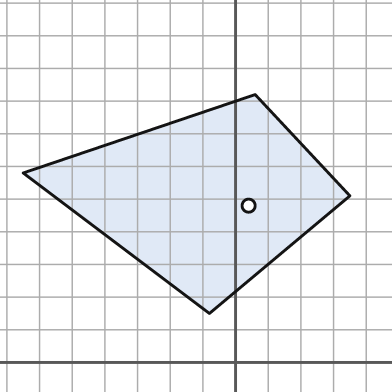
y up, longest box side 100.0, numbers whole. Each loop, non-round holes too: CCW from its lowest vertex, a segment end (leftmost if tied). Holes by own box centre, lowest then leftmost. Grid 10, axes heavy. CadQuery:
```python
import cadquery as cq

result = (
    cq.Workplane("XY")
    .moveTo(-8.0, 15.0)
    .lineTo(35.0, 51.0)
    .lineTo(6.0, 82.0)
    .lineTo(-65.0, 58.0)
    .close()
    .moveTo(4.0, 48.0)
    .circle(2.0)
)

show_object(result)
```